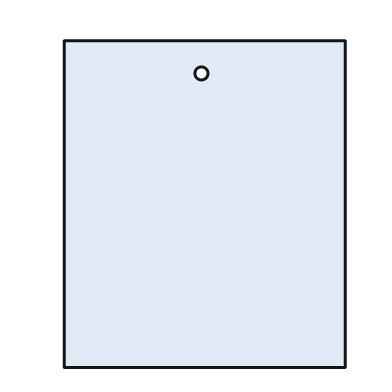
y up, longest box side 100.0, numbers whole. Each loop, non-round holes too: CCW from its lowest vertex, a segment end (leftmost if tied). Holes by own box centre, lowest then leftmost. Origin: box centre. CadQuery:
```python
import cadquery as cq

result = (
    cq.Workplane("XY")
    .moveTo(-43.0, -50.0)
    .lineTo(43.0, -50.0)
    .lineTo(43.0, 50.0)
    .lineTo(-43.0, 50.0)
    .close()
    .moveTo(-1.0, 40.0)
    .circle(2.0)
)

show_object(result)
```